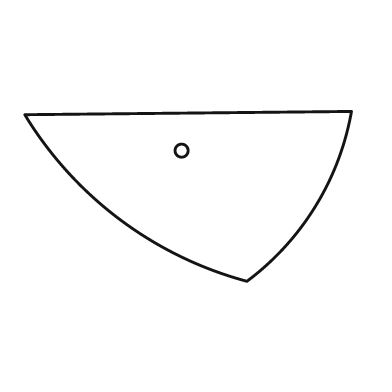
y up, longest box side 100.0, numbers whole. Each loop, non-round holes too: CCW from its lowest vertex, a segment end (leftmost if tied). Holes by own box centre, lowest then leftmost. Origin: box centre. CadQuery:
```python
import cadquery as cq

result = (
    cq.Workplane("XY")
    .moveTo(18.0, -26.0)
    .threePointArc((39.0, -3.0), (50.0, 26.0))
    .lineTo(-50.0, 25.0)
    .threePointArc((-21.0, -7.0), (18.0, -26.0))
    .close()
    .moveTo(-2.0, 14.0)
    .circle(2.0)
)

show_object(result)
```